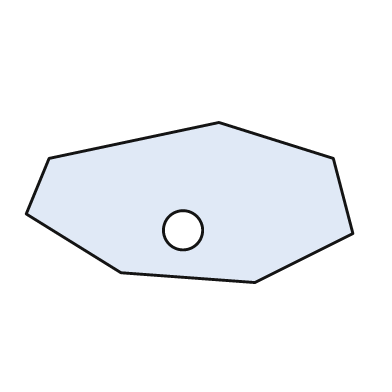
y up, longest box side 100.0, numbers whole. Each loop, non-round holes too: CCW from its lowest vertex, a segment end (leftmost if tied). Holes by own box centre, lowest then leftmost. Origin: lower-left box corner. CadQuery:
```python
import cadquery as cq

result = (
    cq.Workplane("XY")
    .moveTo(70.0, 0.0)
    .lineTo(100.0, 15.0)
    .lineTo(94.0, 38.0)
    .lineTo(59.0, 49.0)
    .lineTo(7.0, 38.0)
    .lineTo(0.0, 21.0)
    .lineTo(29.0, 3.0)
    .close()
    .moveTo(48.0, 16.0)
    .circle(6.0)
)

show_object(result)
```